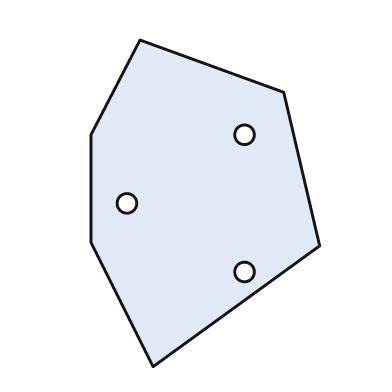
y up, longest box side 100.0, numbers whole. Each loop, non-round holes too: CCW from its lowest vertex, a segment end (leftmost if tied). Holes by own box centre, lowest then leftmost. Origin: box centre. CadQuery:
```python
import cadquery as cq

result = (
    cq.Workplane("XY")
    .moveTo(-16.0, -50.0)
    .lineTo(35.0, -13.0)
    .lineTo(24.0, 34.0)
    .lineTo(-20.0, 50.0)
    .lineTo(-35.0, 21.0)
    .lineTo(-35.0, -12.0)
    .close()
    .moveTo(12.0, -21.0)
    .circle(3.0)
    .moveTo(-24.0, 0.0)
    .circle(3.0)
    .moveTo(12.0, 21.0)
    .circle(3.0)
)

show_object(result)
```